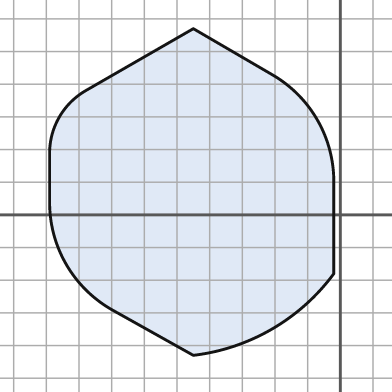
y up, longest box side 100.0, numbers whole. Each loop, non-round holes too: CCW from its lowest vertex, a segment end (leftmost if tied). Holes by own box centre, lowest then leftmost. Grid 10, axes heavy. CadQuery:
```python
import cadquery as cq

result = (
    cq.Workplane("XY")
    .moveTo(-45.0, -43.0)
    .threePointArc((-21.0, -35.0), (-2.0, -18.0))
    .lineTo(-2.0, 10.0)
    .threePointArc((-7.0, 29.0), (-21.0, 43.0))
    .lineTo(-45.0, 57.0)
    .lineTo(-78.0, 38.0)
    .threePointArc((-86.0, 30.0), (-89.0, 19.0))
    .lineTo(-89.0, 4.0)
    .threePointArc((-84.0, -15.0), (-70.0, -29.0))
    .close()
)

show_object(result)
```